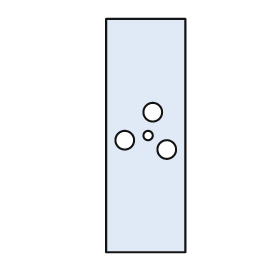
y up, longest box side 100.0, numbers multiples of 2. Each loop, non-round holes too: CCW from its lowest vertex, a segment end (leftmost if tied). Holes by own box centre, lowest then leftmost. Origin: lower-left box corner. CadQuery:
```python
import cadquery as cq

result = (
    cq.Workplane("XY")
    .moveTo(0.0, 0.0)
    .lineTo(34.0, 0.0)
    .lineTo(34.0, 100.0)
    .lineTo(0.0, 100.0)
    .close()
    .moveTo(26.0, 44.0)
    .circle(4.0)
    .moveTo(8.0, 48.0)
    .circle(4.0)
    .moveTo(18.0, 50.0)
    .circle(2.0)
    .moveTo(20.0, 60.0)
    .circle(4.0)
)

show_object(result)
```